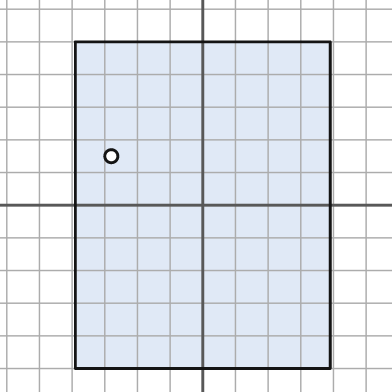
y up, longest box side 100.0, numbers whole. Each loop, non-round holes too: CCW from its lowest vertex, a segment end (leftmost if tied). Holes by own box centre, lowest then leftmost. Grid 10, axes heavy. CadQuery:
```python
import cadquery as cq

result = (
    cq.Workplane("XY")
    .moveTo(-39.0, -50.0)
    .lineTo(39.0, -50.0)
    .lineTo(39.0, 50.0)
    .lineTo(-39.0, 50.0)
    .close()
    .moveTo(-28.0, 15.0)
    .circle(2.0)
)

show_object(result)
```